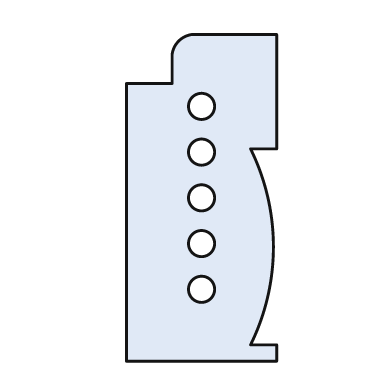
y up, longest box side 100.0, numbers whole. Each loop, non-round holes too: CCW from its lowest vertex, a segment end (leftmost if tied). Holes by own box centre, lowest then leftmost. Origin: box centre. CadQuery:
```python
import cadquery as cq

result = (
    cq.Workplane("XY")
    .moveTo(-23.0, -50.0)
    .lineTo(23.0, -50.0)
    .lineTo(23.0, -45.0)
    .lineTo(15.0, -45.0)
    .threePointArc((22.0, -15.0), (15.0, 15.0))
    .lineTo(23.0, 15.0)
    .lineTo(23.0, 50.0)
    .lineTo(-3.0, 50.0)
    .threePointArc((-7.0, 48.0), (-9.0, 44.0))
    .lineTo(-9.0, 35.0)
    .lineTo(-23.0, 35.0)
    .close()
    .moveTo(0.0, -28.0)
    .circle(4.0)
    .moveTo(0.0, -14.0)
    .circle(4.0)
    .moveTo(0.0, 0.0)
    .circle(4.0)
    .moveTo(0.0, 14.0)
    .circle(4.0)
    .moveTo(0.0, 28.0)
    .circle(4.0)
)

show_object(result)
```